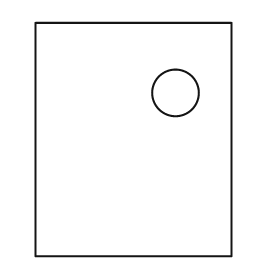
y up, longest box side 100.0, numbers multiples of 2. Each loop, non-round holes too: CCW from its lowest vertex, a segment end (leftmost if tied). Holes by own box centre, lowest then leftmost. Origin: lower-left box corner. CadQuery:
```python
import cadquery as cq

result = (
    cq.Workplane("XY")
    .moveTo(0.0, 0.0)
    .lineTo(84.0, 0.0)
    .lineTo(84.0, 100.0)
    .lineTo(0.0, 100.0)
    .close()
    .moveTo(60.0, 70.0)
    .circle(10.0)
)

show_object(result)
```